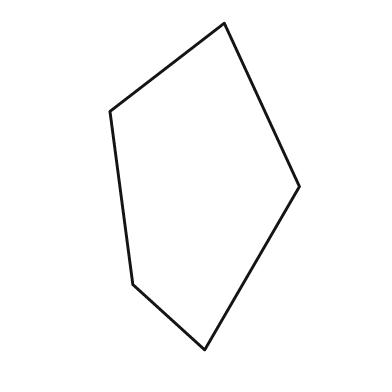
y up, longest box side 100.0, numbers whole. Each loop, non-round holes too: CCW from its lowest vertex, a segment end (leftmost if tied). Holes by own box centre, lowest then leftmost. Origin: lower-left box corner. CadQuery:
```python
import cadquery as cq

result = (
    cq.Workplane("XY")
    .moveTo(29.0, 0.0)
    .lineTo(58.0, 50.0)
    .lineTo(35.0, 100.0)
    .lineTo(0.0, 73.0)
    .lineTo(7.0, 20.0)
    .close()
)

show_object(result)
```